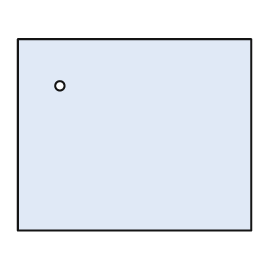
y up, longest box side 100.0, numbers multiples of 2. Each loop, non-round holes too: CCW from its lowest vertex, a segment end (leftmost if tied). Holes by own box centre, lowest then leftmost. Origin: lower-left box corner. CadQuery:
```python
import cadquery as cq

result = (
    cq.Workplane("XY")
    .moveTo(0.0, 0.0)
    .lineTo(100.0, 0.0)
    .lineTo(100.0, 82.0)
    .lineTo(0.0, 82.0)
    .close()
    .moveTo(18.0, 62.0)
    .circle(2.0)
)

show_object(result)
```